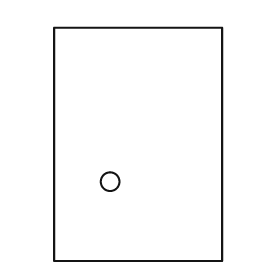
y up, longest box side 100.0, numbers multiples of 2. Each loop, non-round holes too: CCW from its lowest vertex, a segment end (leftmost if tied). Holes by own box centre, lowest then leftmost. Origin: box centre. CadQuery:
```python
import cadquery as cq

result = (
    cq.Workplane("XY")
    .moveTo(-36.0, -50.0)
    .lineTo(36.0, -50.0)
    .lineTo(36.0, 50.0)
    .lineTo(-36.0, 50.0)
    .close()
    .moveTo(-12.0, -16.0)
    .circle(4.0)
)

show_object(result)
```